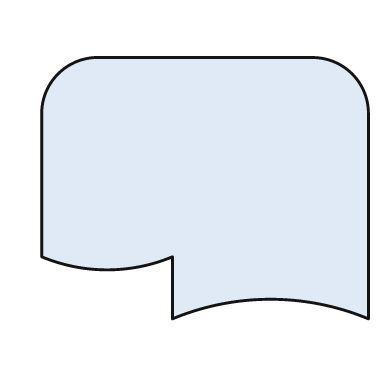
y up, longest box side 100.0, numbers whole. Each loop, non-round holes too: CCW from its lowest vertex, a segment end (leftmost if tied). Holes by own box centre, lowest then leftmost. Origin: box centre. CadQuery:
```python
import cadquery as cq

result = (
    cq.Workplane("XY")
    .moveTo(-10.0, -40.0)
    .threePointArc((20.0, -34.0), (50.0, -40.0))
    .lineTo(50.0, 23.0)
    .threePointArc((45.0, 35.0), (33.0, 40.0))
    .lineTo(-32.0, 40.0)
    .threePointArc((-45.0, 35.0), (-50.0, 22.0))
    .lineTo(-50.0, -21.0)
    .threePointArc((-30.0, -25.0), (-10.0, -21.0))
    .close()
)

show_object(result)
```